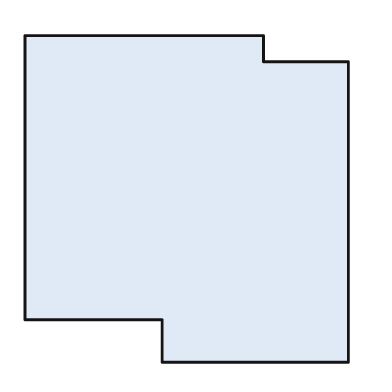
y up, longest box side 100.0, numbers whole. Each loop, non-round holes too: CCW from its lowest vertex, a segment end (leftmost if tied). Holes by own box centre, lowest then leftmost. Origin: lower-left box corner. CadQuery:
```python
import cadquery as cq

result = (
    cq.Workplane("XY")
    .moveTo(42.0, 0.0)
    .lineTo(99.0, 0.0)
    .lineTo(99.0, 92.0)
    .lineTo(73.0, 92.0)
    .lineTo(73.0, 100.0)
    .lineTo(0.0, 100.0)
    .lineTo(0.0, 13.0)
    .lineTo(42.0, 13.0)
    .close()
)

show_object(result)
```